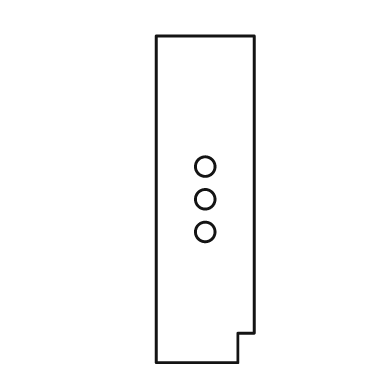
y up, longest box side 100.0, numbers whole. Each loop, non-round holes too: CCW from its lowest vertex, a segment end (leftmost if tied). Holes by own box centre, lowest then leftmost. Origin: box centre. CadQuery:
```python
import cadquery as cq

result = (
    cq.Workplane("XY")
    .moveTo(-15.0, -50.0)
    .lineTo(10.0, -50.0)
    .lineTo(10.0, -41.0)
    .lineTo(15.0, -41.0)
    .lineTo(15.0, 50.0)
    .lineTo(-15.0, 50.0)
    .close()
    .moveTo(0.0, -10.0)
    .circle(3.0)
    .moveTo(0.0, 0.0)
    .circle(3.0)
    .moveTo(0.0, 10.0)
    .circle(3.0)
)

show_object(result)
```